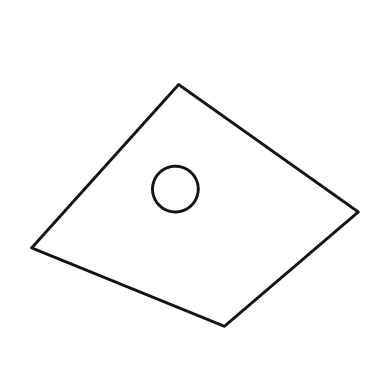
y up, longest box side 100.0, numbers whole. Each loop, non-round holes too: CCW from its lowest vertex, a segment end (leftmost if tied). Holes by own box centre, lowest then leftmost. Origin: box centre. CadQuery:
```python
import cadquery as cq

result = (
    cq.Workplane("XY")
    .moveTo(9.0, -37.0)
    .lineTo(50.0, -2.0)
    .lineTo(-5.0, 37.0)
    .lineTo(-50.0, -13.0)
    .close()
    .moveTo(-6.0, 5.0)
    .circle(7.0)
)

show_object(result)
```